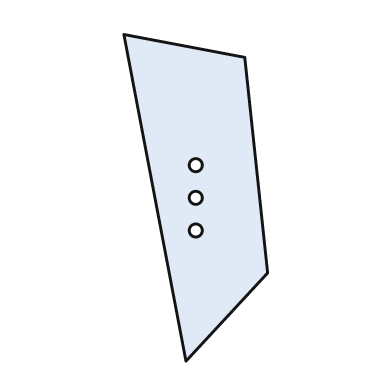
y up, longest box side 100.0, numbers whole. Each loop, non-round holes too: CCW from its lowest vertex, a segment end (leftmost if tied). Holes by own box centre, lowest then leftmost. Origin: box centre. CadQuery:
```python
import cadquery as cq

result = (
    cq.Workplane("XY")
    .moveTo(-3.0, -50.0)
    .lineTo(22.0, -23.0)
    .lineTo(15.0, 43.0)
    .lineTo(-22.0, 50.0)
    .close()
    .moveTo(0.0, -10.0)
    .circle(2.0)
    .moveTo(0.0, 0.0)
    .circle(2.0)
    .moveTo(0.0, 10.0)
    .circle(2.0)
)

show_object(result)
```